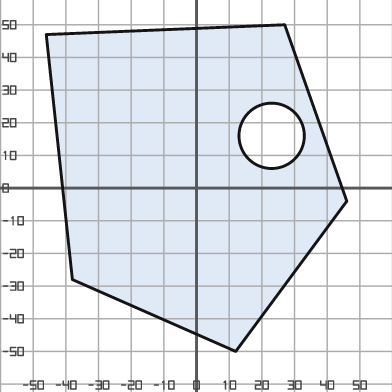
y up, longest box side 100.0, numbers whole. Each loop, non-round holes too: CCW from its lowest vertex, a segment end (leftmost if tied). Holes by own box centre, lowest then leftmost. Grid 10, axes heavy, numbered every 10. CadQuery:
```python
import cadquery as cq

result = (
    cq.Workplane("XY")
    .moveTo(12.0, -50.0)
    .lineTo(46.0, -4.0)
    .lineTo(27.0, 50.0)
    .lineTo(-46.0, 47.0)
    .lineTo(-38.0, -28.0)
    .close()
    .moveTo(23.0, 16.0)
    .circle(10.0)
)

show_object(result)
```